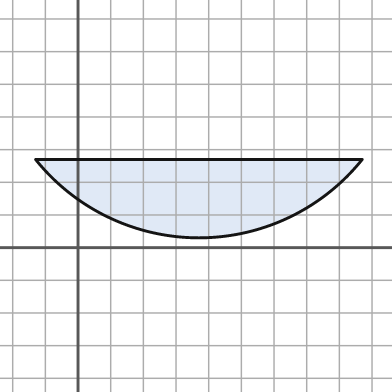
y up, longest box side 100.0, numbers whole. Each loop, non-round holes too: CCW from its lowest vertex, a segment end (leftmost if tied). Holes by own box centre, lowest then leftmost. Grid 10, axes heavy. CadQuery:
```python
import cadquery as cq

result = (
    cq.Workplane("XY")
    .moveTo(-13.0, 27.0)
    .threePointArc((37.0, 3.0), (87.0, 27.0))
    .close()
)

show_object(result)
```